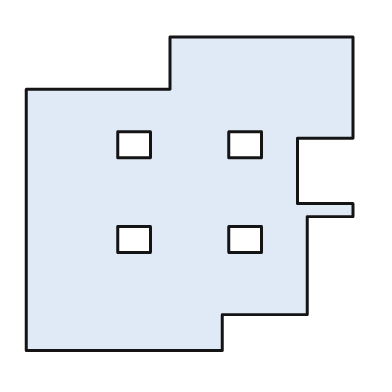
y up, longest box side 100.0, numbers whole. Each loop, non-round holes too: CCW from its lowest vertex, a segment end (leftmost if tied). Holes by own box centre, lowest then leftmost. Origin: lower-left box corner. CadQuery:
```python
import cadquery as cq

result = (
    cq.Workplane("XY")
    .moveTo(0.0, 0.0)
    .lineTo(60.0, 0.0)
    .lineTo(60.0, 11.0)
    .lineTo(86.0, 11.0)
    .lineTo(86.0, 41.0)
    .lineTo(100.0, 41.0)
    .lineTo(100.0, 45.0)
    .lineTo(83.0, 45.0)
    .lineTo(83.0, 65.0)
    .lineTo(100.0, 65.0)
    .lineTo(100.0, 96.0)
    .lineTo(44.0, 96.0)
    .lineTo(44.0, 80.0)
    .lineTo(0.0, 80.0)
    .close()
    .moveTo(28.0, 30.0)
    .lineTo(38.0, 30.0)
    .lineTo(38.0, 38.0)
    .lineTo(28.0, 38.0)
    .close()
    .moveTo(62.0, 30.0)
    .lineTo(72.0, 30.0)
    .lineTo(72.0, 38.0)
    .lineTo(62.0, 38.0)
    .close()
    .moveTo(28.0, 59.0)
    .lineTo(38.0, 59.0)
    .lineTo(38.0, 67.0)
    .lineTo(28.0, 67.0)
    .close()
    .moveTo(62.0, 59.0)
    .lineTo(72.0, 59.0)
    .lineTo(72.0, 67.0)
    .lineTo(62.0, 67.0)
    .close()
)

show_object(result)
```